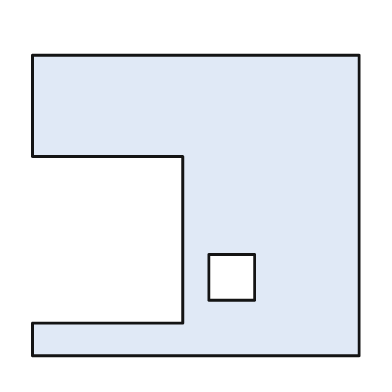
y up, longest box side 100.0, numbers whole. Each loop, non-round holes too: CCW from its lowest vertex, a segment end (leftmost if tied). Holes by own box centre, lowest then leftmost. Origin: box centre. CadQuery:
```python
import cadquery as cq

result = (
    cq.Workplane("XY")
    .moveTo(-50.0, -46.0)
    .lineTo(50.0, -46.0)
    .lineTo(50.0, 46.0)
    .lineTo(-50.0, 46.0)
    .lineTo(-50.0, 15.0)
    .lineTo(-4.0, 15.0)
    .lineTo(-4.0, -36.0)
    .lineTo(-50.0, -36.0)
    .close()
    .moveTo(4.0, -29.0)
    .lineTo(18.0, -29.0)
    .lineTo(18.0, -15.0)
    .lineTo(4.0, -15.0)
    .close()
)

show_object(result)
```